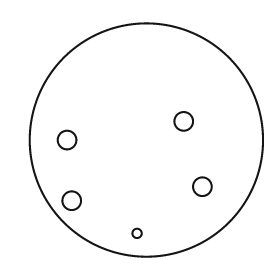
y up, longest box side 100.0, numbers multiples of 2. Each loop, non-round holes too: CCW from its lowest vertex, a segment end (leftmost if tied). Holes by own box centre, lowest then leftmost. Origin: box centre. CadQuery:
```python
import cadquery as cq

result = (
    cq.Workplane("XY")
    .moveTo(0.0, 0.0)
    .circle(50.0)
    .moveTo(-4.0, -40.0)
    .circle(2.0)
    .moveTo(-32.0, -26.0)
    .circle(4.0)
    .moveTo(24.0, -20.0)
    .circle(4.0)
    .moveTo(-34.0, 0.0)
    .circle(4.0)
    .moveTo(16.0, 8.0)
    .circle(4.0)
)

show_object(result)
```